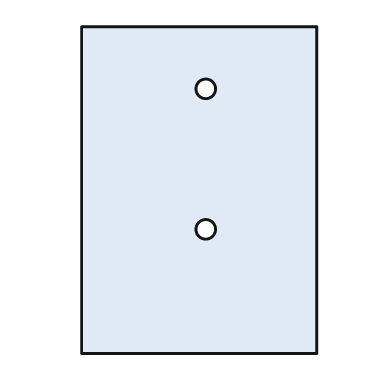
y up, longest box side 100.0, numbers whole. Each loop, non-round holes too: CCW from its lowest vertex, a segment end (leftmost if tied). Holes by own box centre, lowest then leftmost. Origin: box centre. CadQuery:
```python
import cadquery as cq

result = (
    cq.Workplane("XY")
    .moveTo(-36.0, -50.0)
    .lineTo(36.0, -50.0)
    .lineTo(36.0, 50.0)
    .lineTo(-36.0, 50.0)
    .close()
    .moveTo(2.0, -12.0)
    .circle(3.0)
    .moveTo(2.0, 31.0)
    .circle(3.0)
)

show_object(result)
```